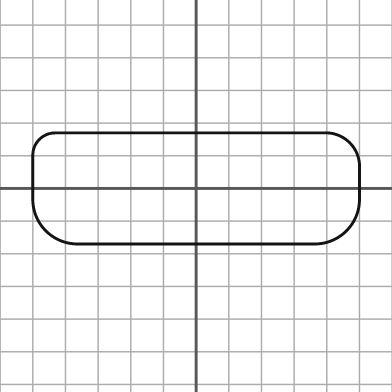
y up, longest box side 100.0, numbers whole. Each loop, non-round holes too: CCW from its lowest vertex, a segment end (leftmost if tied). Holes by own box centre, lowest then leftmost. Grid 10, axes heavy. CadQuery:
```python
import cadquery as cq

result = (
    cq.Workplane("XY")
    .moveTo(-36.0, -17.0)
    .lineTo(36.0, -17.0)
    .threePointArc((46.0, -13.0), (50.0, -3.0))
    .lineTo(50.0, 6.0)
    .threePointArc((47.0, 14.0), (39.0, 17.0))
    .lineTo(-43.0, 17.0)
    .threePointArc((-48.0, 15.0), (-50.0, 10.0))
    .lineTo(-50.0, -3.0)
    .threePointArc((-46.0, -13.0), (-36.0, -17.0))
    .close()
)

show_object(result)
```